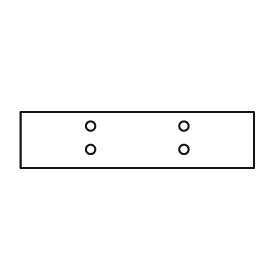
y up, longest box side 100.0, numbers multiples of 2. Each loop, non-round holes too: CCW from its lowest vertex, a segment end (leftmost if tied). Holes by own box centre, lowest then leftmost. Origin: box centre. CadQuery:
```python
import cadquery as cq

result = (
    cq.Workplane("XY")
    .moveTo(-50.0, -12.0)
    .lineTo(50.0, -12.0)
    .lineTo(50.0, 12.0)
    .lineTo(-50.0, 12.0)
    .close()
    .moveTo(-20.0, -4.0)
    .circle(2.0)
    .moveTo(20.0, -4.0)
    .circle(2.0)
    .moveTo(-20.0, 6.0)
    .circle(2.0)
    .moveTo(20.0, 6.0)
    .circle(2.0)
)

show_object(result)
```